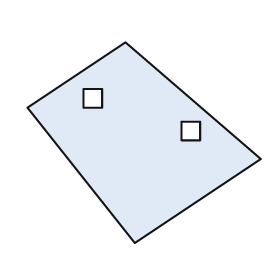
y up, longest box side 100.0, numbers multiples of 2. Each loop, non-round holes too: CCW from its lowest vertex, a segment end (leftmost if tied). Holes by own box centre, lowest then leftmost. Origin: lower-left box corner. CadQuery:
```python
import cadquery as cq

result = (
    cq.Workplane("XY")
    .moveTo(46.0, 0.0)
    .lineTo(100.0, 36.0)
    .lineTo(42.0, 86.0)
    .lineTo(0.0, 58.0)
    .close()
    .moveTo(66.0, 44.0)
    .lineTo(74.0, 44.0)
    .lineTo(74.0, 52.0)
    .lineTo(66.0, 52.0)
    .close()
    .moveTo(24.0, 58.0)
    .lineTo(32.0, 58.0)
    .lineTo(32.0, 66.0)
    .lineTo(24.0, 66.0)
    .close()
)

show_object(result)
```